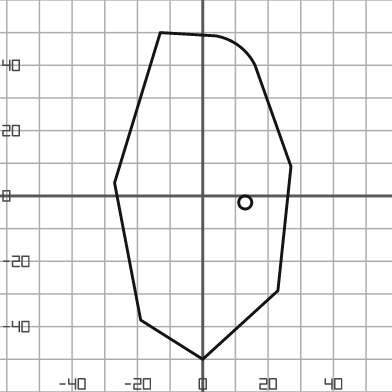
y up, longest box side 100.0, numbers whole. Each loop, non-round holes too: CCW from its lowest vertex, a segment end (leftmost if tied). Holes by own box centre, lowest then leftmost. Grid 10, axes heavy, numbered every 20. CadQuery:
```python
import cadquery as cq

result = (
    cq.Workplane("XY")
    .moveTo(0.0, -50.0)
    .lineTo(23.0, -29.0)
    .lineTo(27.0, 9.0)
    .lineTo(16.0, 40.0)
    .threePointArc((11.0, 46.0), (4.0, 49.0))
    .lineTo(-13.0, 50.0)
    .lineTo(-27.0, 4.0)
    .lineTo(-19.0, -38.0)
    .close()
    .moveTo(13.0, -2.0)
    .circle(2.0)
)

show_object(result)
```